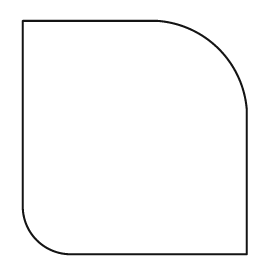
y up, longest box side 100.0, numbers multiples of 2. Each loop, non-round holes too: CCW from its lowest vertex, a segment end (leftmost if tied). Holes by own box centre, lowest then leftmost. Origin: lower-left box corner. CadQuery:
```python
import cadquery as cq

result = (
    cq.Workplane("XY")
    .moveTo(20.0, 0.0)
    .lineTo(96.0, 0.0)
    .lineTo(96.0, 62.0)
    .threePointArc((84.0, 88.0), (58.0, 100.0))
    .lineTo(0.0, 100.0)
    .lineTo(0.0, 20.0)
    .threePointArc((6.0, 6.0), (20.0, 0.0))
    .close()
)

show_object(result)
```